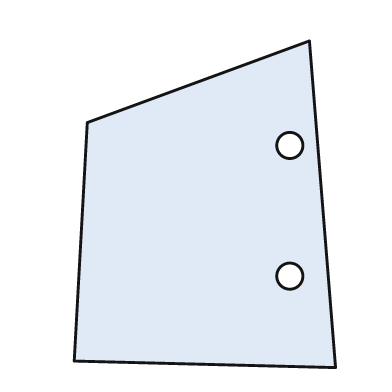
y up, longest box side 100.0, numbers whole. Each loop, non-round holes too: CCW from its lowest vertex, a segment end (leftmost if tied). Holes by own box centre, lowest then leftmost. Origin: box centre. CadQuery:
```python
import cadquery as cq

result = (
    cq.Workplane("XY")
    .moveTo(40.0, -50.0)
    .lineTo(32.0, 50.0)
    .lineTo(-36.0, 25.0)
    .lineTo(-40.0, -48.0)
    .close()
    .moveTo(26.0, -22.0)
    .circle(4.0)
    .moveTo(26.0, 18.0)
    .circle(4.0)
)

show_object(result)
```